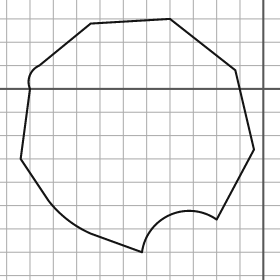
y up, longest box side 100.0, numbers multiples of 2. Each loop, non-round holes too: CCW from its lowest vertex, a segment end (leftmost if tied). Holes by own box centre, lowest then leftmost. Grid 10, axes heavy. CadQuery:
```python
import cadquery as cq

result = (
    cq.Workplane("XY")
    .moveTo(-52.0, -70.0)
    .threePointArc((-40.0, -54.0), (-20.0, -56.0))
    .lineTo(-4.0, -26.0)
    .lineTo(-12.0, 8.0)
    .lineTo(-40.0, 30.0)
    .lineTo(-74.0, 28.0)
    .lineTo(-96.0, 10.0)
    .threePointArc((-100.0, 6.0), (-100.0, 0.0))
    .lineTo(-104.0, -30.0)
    .lineTo(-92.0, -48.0)
    .threePointArc((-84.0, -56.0), (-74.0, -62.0))
    .close()
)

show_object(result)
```